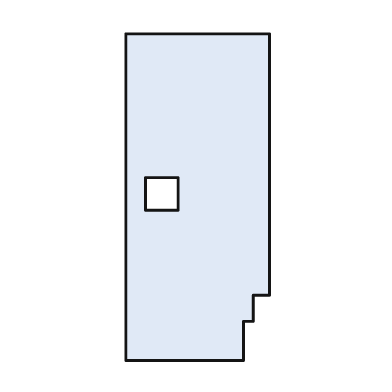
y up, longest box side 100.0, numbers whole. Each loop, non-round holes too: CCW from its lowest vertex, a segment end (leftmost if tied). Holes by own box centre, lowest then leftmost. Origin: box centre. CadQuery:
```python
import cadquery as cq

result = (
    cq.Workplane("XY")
    .moveTo(-22.0, -50.0)
    .lineTo(14.0, -50.0)
    .lineTo(14.0, -38.0)
    .lineTo(17.0, -38.0)
    .lineTo(17.0, -30.0)
    .lineTo(22.0, -30.0)
    .lineTo(22.0, 50.0)
    .lineTo(-22.0, 50.0)
    .close()
    .moveTo(-16.0, -4.0)
    .lineTo(-6.0, -4.0)
    .lineTo(-6.0, 6.0)
    .lineTo(-16.0, 6.0)
    .close()
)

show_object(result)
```